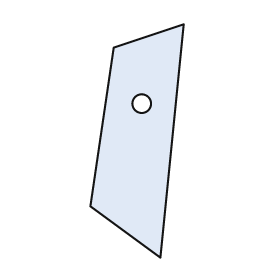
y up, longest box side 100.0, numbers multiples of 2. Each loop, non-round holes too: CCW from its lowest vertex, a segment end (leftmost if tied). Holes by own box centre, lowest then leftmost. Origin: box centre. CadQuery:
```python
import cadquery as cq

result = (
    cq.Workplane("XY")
    .moveTo(10.0, -50.0)
    .lineTo(20.0, 50.0)
    .lineTo(-10.0, 40.0)
    .lineTo(-20.0, -28.0)
    .close()
    .moveTo(2.0, 16.0)
    .circle(4.0)
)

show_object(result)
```